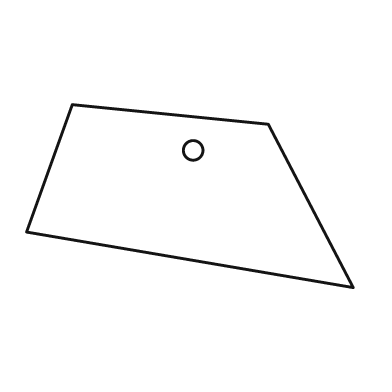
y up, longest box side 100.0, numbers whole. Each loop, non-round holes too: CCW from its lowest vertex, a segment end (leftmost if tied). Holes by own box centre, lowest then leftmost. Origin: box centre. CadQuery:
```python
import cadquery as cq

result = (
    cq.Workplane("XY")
    .moveTo(50.0, -28.0)
    .lineTo(24.0, 22.0)
    .lineTo(-36.0, 28.0)
    .lineTo(-50.0, -11.0)
    .close()
    .moveTo(1.0, 14.0)
    .circle(3.0)
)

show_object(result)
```